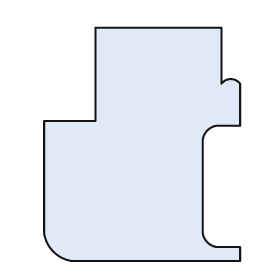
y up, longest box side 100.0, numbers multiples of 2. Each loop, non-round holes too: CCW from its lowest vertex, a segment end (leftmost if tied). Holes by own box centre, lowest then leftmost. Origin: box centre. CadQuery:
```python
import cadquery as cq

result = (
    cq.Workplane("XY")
    .moveTo(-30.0, -50.0)
    .lineTo(42.0, -50.0)
    .lineTo(42.0, -44.0)
    .lineTo(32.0, -44.0)
    .threePointArc((28.0, -42.0), (26.0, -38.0))
    .lineTo(26.0, 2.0)
    .threePointArc((28.0, 6.0), (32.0, 8.0))
    .lineTo(42.0, 8.0)
    .lineTo(42.0, 26.0)
    .threePointArc((38.0, 28.0), (34.0, 26.0))
    .lineTo(34.0, 50.0)
    .lineTo(-20.0, 50.0)
    .lineTo(-20.0, 10.0)
    .lineTo(-42.0, 10.0)
    .lineTo(-42.0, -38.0)
    .threePointArc((-38.0, -46.0), (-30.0, -50.0))
    .close()
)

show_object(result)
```